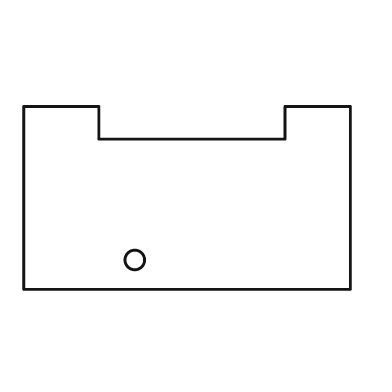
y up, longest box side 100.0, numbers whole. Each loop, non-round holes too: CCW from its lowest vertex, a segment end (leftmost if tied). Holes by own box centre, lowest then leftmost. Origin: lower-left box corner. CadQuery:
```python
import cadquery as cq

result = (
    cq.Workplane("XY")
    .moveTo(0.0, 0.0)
    .lineTo(100.0, 0.0)
    .lineTo(100.0, 56.0)
    .lineTo(80.0, 56.0)
    .lineTo(80.0, 46.0)
    .lineTo(23.0, 46.0)
    .lineTo(23.0, 56.0)
    .lineTo(0.0, 56.0)
    .close()
    .moveTo(34.0, 9.0)
    .circle(3.0)
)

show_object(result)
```